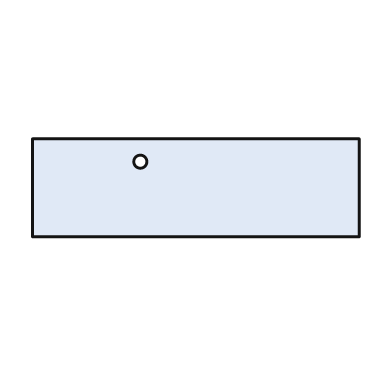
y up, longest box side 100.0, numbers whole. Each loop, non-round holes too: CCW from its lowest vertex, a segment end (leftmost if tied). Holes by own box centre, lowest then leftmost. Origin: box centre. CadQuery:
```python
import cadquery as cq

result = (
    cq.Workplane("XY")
    .moveTo(-50.0, -15.0)
    .lineTo(50.0, -15.0)
    .lineTo(50.0, 15.0)
    .lineTo(-50.0, 15.0)
    .close()
    .moveTo(-17.0, 8.0)
    .circle(2.0)
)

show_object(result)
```